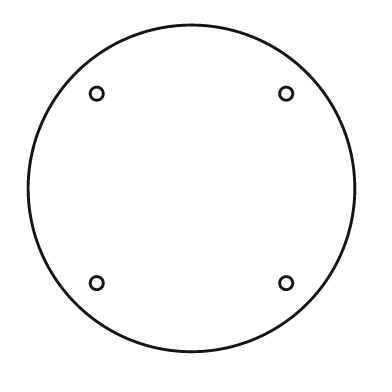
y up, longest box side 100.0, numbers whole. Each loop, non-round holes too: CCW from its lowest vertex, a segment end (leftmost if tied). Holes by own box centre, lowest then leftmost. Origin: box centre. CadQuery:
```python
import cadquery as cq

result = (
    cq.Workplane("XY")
    .moveTo(0.0, 0.0)
    .circle(50.0)
    .moveTo(-29.0, -29.0)
    .circle(2.0)
    .moveTo(29.0, -29.0)
    .circle(2.0)
    .moveTo(-29.0, 29.0)
    .circle(2.0)
    .moveTo(29.0, 29.0)
    .circle(2.0)
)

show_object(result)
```